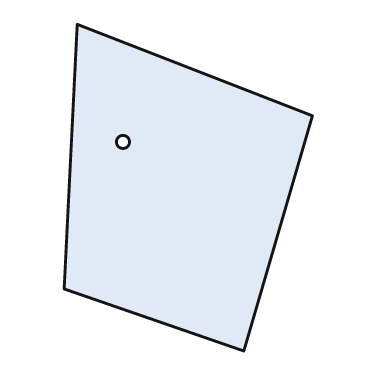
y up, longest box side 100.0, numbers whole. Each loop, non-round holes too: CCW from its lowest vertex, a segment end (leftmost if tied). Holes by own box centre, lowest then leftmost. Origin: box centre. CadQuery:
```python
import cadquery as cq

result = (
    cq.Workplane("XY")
    .moveTo(17.0, -50.0)
    .lineTo(38.0, 22.0)
    .lineTo(-34.0, 50.0)
    .lineTo(-38.0, -31.0)
    .close()
    .moveTo(-20.0, 14.0)
    .circle(2.0)
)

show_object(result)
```